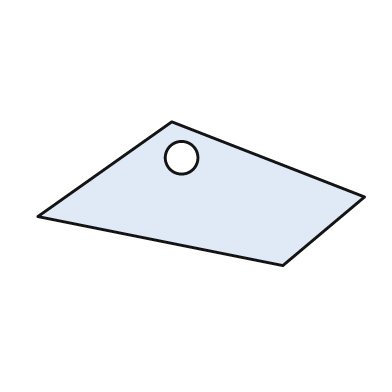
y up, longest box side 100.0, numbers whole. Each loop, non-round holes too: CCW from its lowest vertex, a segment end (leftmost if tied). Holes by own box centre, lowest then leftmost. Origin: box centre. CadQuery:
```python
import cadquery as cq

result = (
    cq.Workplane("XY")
    .moveTo(25.0, -22.0)
    .lineTo(50.0, -1.0)
    .lineTo(-9.0, 22.0)
    .lineTo(-50.0, -7.0)
    .close()
    .moveTo(-6.0, 11.0)
    .circle(5.0)
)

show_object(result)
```